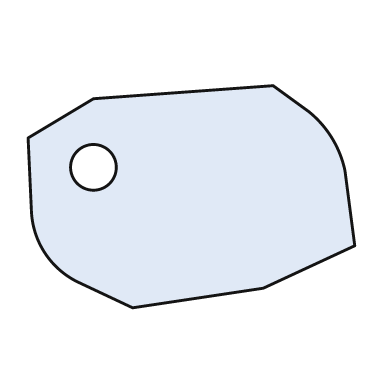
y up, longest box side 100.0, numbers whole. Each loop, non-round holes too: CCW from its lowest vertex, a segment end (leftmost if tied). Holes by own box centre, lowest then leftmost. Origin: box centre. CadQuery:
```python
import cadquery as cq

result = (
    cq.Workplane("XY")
    .moveTo(-18.0, -34.0)
    .lineTo(22.0, -28.0)
    .lineTo(50.0, -15.0)
    .lineTo(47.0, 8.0)
    .threePointArc((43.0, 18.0), (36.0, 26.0))
    .lineTo(25.0, 34.0)
    .lineTo(-30.0, 30.0)
    .lineTo(-50.0, 18.0)
    .lineTo(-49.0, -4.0)
    .threePointArc((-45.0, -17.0), (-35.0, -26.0))
    .close()
    .moveTo(-30.0, 9.0)
    .circle(7.0)
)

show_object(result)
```